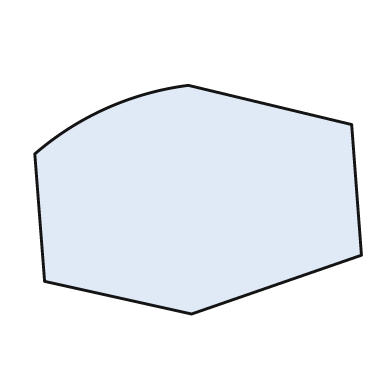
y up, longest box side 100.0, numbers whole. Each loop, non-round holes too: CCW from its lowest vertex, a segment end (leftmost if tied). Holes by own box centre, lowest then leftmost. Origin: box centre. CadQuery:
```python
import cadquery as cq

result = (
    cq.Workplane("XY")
    .moveTo(-2.0, -35.0)
    .lineTo(50.0, -17.0)
    .lineTo(47.0, 23.0)
    .lineTo(-3.0, 35.0)
    .threePointArc((-28.0, 28.0), (-50.0, 14.0))
    .lineTo(-47.0, -25.0)
    .close()
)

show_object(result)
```